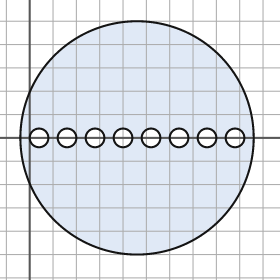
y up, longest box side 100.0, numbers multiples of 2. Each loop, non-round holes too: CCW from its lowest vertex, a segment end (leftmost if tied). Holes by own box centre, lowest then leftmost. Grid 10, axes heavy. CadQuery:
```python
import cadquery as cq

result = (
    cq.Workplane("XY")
    .moveTo(46.0, 0.0)
    .circle(50.0)
    .moveTo(4.0, 0.0)
    .circle(4.0)
    .moveTo(16.0, 0.0)
    .circle(4.0)
    .moveTo(28.0, 0.0)
    .circle(4.0)
    .moveTo(40.0, 0.0)
    .circle(4.0)
    .moveTo(52.0, 0.0)
    .circle(4.0)
    .moveTo(64.0, 0.0)
    .circle(4.0)
    .moveTo(76.0, 0.0)
    .circle(4.0)
    .moveTo(88.0, 0.0)
    .circle(4.0)
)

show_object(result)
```